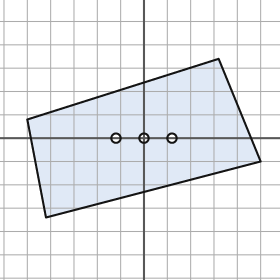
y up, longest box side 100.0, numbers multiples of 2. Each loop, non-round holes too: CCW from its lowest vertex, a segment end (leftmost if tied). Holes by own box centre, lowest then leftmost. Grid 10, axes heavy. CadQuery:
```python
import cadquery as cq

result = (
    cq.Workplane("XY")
    .moveTo(-42.0, -34.0)
    .lineTo(50.0, -10.0)
    .lineTo(32.0, 34.0)
    .lineTo(-50.0, 8.0)
    .close()
    .moveTo(-12.0, 0.0)
    .circle(2.0)
    .moveTo(0.0, 0.0)
    .circle(2.0)
    .moveTo(12.0, 0.0)
    .circle(2.0)
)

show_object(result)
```